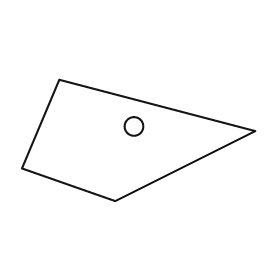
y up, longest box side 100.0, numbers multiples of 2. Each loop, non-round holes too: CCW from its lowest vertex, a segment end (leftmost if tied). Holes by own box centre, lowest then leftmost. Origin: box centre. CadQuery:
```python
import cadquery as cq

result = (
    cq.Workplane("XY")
    .moveTo(-10.0, -26.0)
    .lineTo(50.0, 4.0)
    .lineTo(-34.0, 26.0)
    .lineTo(-50.0, -12.0)
    .close()
    .moveTo(-2.0, 6.0)
    .circle(4.0)
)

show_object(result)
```